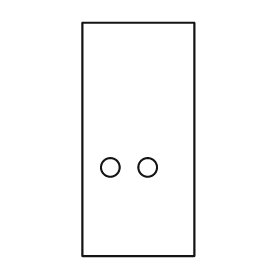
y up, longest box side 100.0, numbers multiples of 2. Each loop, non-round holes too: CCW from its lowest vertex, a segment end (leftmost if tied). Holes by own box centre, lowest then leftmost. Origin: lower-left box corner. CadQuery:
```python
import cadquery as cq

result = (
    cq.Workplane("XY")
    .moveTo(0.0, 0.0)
    .lineTo(48.0, 0.0)
    .lineTo(48.0, 100.0)
    .lineTo(0.0, 100.0)
    .close()
    .moveTo(12.0, 38.0)
    .circle(4.0)
    .moveTo(28.0, 38.0)
    .circle(4.0)
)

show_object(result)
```